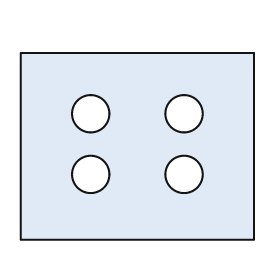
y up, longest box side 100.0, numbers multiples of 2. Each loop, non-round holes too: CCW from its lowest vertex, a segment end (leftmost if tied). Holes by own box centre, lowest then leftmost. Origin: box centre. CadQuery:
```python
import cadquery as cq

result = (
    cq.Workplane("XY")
    .moveTo(-50.0, -40.0)
    .lineTo(50.0, -40.0)
    .lineTo(50.0, 40.0)
    .lineTo(-50.0, 40.0)
    .close()
    .moveTo(-20.0, -12.0)
    .circle(8.0)
    .moveTo(20.0, -12.0)
    .circle(8.0)
    .moveTo(-20.0, 14.0)
    .circle(8.0)
    .moveTo(20.0, 14.0)
    .circle(8.0)
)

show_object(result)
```